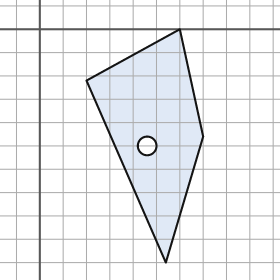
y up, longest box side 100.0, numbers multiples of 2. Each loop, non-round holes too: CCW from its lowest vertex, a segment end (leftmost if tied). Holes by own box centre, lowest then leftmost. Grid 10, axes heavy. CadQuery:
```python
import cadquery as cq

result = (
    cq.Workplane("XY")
    .moveTo(54.0, -100.0)
    .lineTo(70.0, -46.0)
    .lineTo(60.0, 0.0)
    .lineTo(20.0, -22.0)
    .close()
    .moveTo(46.0, -50.0)
    .circle(4.0)
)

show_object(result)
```